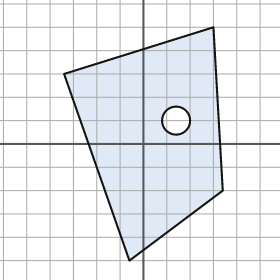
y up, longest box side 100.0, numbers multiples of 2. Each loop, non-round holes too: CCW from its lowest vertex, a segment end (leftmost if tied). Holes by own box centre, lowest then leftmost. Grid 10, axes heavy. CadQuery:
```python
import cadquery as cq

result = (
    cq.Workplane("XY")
    .moveTo(-6.0, -50.0)
    .lineTo(34.0, -20.0)
    .lineTo(30.0, 50.0)
    .lineTo(-34.0, 30.0)
    .close()
    .moveTo(14.0, 10.0)
    .circle(6.0)
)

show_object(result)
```